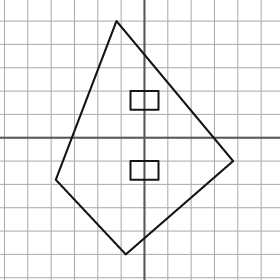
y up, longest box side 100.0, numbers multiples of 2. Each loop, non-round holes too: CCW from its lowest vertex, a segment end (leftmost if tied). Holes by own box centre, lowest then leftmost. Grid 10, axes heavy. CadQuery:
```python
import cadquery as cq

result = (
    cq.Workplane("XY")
    .moveTo(-8.0, -50.0)
    .lineTo(38.0, -10.0)
    .lineTo(-12.0, 50.0)
    .lineTo(-38.0, -18.0)
    .close()
    .moveTo(-6.0, -18.0)
    .lineTo(6.0, -18.0)
    .lineTo(6.0, -10.0)
    .lineTo(-6.0, -10.0)
    .close()
    .moveTo(-6.0, 12.0)
    .lineTo(6.0, 12.0)
    .lineTo(6.0, 20.0)
    .lineTo(-6.0, 20.0)
    .close()
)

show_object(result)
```